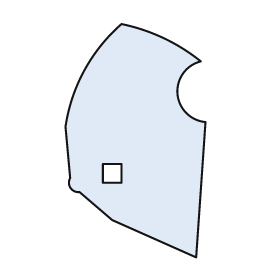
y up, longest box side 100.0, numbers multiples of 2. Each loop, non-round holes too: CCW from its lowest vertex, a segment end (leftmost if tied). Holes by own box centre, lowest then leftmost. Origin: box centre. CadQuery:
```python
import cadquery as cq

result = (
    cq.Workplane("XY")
    .moveTo(26.0, -50.0)
    .lineTo(30.0, 8.0)
    .threePointArc((18.0, 20.0), (28.0, 34.0))
    .threePointArc((12.0, 44.0), (-6.0, 50.0))
    .threePointArc((-22.0, 30.0), (-30.0, 6.0))
    .lineTo(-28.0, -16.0)
    .threePointArc((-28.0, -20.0), (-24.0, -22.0))
    .lineTo(-10.0, -34.0)
    .close()
    .moveTo(-14.0, -18.0)
    .lineTo(-6.0, -18.0)
    .lineTo(-6.0, -10.0)
    .lineTo(-14.0, -10.0)
    .close()
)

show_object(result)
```